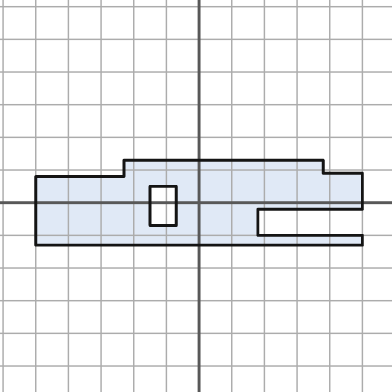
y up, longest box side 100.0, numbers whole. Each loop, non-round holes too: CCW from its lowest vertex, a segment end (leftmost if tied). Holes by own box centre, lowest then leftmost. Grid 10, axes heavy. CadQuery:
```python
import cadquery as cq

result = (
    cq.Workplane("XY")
    .moveTo(-50.0, -13.0)
    .lineTo(50.0, -13.0)
    .lineTo(50.0, -10.0)
    .lineTo(18.0, -10.0)
    .lineTo(18.0, -2.0)
    .lineTo(50.0, -2.0)
    .lineTo(50.0, 9.0)
    .lineTo(38.0, 9.0)
    .lineTo(38.0, 13.0)
    .lineTo(-23.0, 13.0)
    .lineTo(-23.0, 8.0)
    .lineTo(-50.0, 8.0)
    .close()
    .moveTo(-15.0, -7.0)
    .lineTo(-7.0, -7.0)
    .lineTo(-7.0, 5.0)
    .lineTo(-15.0, 5.0)
    .close()
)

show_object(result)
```